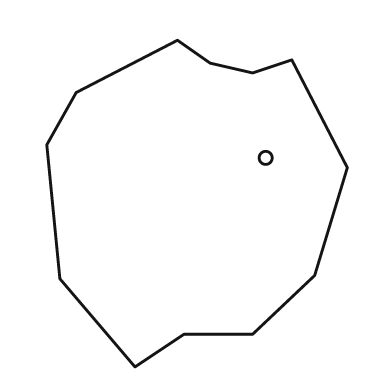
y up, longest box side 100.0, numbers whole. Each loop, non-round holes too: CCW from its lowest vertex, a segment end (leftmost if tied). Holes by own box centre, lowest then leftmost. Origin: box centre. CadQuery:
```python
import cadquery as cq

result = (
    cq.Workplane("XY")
    .moveTo(-19.0, -50.0)
    .lineTo(-4.0, -40.0)
    .lineTo(17.0, -40.0)
    .lineTo(36.0, -22.0)
    .lineTo(46.0, 11.0)
    .lineTo(29.0, 44.0)
    .lineTo(17.0, 40.0)
    .lineTo(4.0, 43.0)
    .lineTo(-6.0, 50.0)
    .lineTo(-37.0, 34.0)
    .lineTo(-46.0, 18.0)
    .lineTo(-42.0, -23.0)
    .close()
    .moveTo(21.0, 14.0)
    .circle(2.0)
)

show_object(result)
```